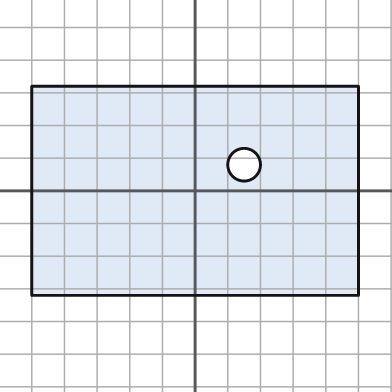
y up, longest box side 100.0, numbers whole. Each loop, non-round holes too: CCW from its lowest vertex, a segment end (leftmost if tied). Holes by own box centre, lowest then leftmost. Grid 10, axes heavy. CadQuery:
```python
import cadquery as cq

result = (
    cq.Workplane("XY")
    .moveTo(-50.0, -32.0)
    .lineTo(50.0, -32.0)
    .lineTo(50.0, 32.0)
    .lineTo(-50.0, 32.0)
    .close()
    .moveTo(15.0, 8.0)
    .circle(5.0)
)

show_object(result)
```